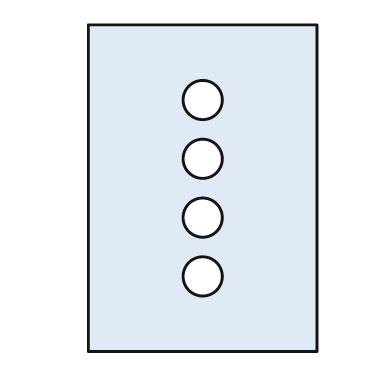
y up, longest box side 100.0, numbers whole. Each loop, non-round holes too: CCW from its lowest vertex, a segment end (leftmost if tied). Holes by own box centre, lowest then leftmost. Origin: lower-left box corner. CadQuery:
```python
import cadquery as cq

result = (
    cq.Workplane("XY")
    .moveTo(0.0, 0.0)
    .lineTo(70.0, 0.0)
    .lineTo(70.0, 100.0)
    .lineTo(0.0, 100.0)
    .close()
    .moveTo(35.0, 23.0)
    .circle(6.0)
    .moveTo(35.0, 41.0)
    .circle(6.0)
    .moveTo(35.0, 59.0)
    .circle(6.0)
    .moveTo(35.0, 77.0)
    .circle(6.0)
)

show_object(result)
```